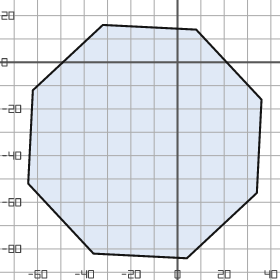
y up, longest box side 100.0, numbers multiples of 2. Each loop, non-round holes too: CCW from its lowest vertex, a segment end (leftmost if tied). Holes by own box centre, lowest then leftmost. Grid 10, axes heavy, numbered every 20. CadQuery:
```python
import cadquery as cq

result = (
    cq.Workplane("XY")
    .moveTo(4.0, -84.0)
    .lineTo(34.0, -56.0)
    .lineTo(36.0, -16.0)
    .lineTo(8.0, 14.0)
    .lineTo(-32.0, 16.0)
    .lineTo(-62.0, -12.0)
    .lineTo(-64.0, -52.0)
    .lineTo(-36.0, -82.0)
    .close()
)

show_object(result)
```